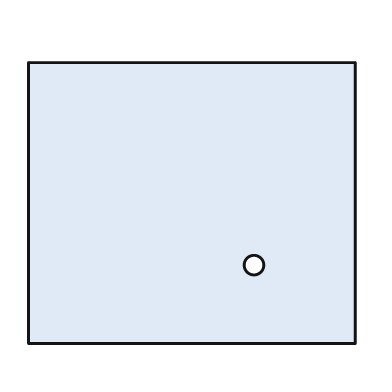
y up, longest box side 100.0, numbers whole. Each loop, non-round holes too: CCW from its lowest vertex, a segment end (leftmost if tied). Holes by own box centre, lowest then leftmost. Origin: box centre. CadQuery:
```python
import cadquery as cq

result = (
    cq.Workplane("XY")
    .moveTo(-50.0, -43.0)
    .lineTo(50.0, -43.0)
    .lineTo(50.0, 43.0)
    .lineTo(-50.0, 43.0)
    .close()
    .moveTo(19.0, -19.0)
    .circle(3.0)
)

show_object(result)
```